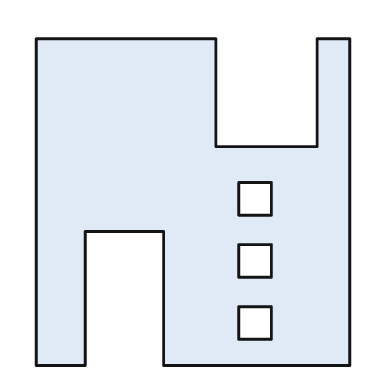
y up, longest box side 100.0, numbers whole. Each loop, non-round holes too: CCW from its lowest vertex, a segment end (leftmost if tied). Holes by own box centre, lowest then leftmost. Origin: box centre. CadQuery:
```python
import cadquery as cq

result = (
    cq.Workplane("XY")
    .moveTo(-48.0, -50.0)
    .lineTo(-33.0, -50.0)
    .lineTo(-33.0, -9.0)
    .lineTo(-9.0, -9.0)
    .lineTo(-9.0, -50.0)
    .lineTo(48.0, -50.0)
    .lineTo(48.0, 50.0)
    .lineTo(38.0, 50.0)
    .lineTo(38.0, 17.0)
    .lineTo(7.0, 17.0)
    .lineTo(7.0, 50.0)
    .lineTo(-48.0, 50.0)
    .close()
    .moveTo(14.0, -42.0)
    .lineTo(24.0, -42.0)
    .lineTo(24.0, -32.0)
    .lineTo(14.0, -32.0)
    .close()
    .moveTo(14.0, -23.0)
    .lineTo(24.0, -23.0)
    .lineTo(24.0, -13.0)
    .lineTo(14.0, -13.0)
    .close()
    .moveTo(14.0, -4.0)
    .lineTo(24.0, -4.0)
    .lineTo(24.0, 6.0)
    .lineTo(14.0, 6.0)
    .close()
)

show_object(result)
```